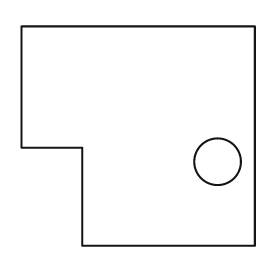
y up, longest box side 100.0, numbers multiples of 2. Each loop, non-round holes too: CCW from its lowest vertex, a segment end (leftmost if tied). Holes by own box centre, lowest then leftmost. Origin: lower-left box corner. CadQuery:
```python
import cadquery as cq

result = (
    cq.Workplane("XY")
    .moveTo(26.0, 0.0)
    .lineTo(100.0, 0.0)
    .lineTo(100.0, 94.0)
    .lineTo(0.0, 94.0)
    .lineTo(0.0, 42.0)
    .lineTo(26.0, 42.0)
    .close()
    .moveTo(84.0, 36.0)
    .circle(10.0)
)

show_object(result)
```